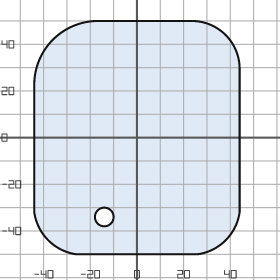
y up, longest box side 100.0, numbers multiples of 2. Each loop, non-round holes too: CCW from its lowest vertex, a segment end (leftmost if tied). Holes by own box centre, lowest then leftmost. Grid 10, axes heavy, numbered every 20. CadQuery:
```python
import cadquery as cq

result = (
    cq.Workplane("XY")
    .moveTo(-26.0, -50.0)
    .lineTo(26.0, -50.0)
    .threePointArc((38.0, -44.0), (44.0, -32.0))
    .lineTo(44.0, 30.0)
    .threePointArc((38.0, 44.0), (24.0, 50.0))
    .lineTo(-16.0, 50.0)
    .threePointArc((-36.0, 42.0), (-44.0, 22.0))
    .lineTo(-44.0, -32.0)
    .threePointArc((-38.0, -44.0), (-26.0, -50.0))
    .close()
    .moveTo(-14.0, -34.0)
    .circle(4.0)
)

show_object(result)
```